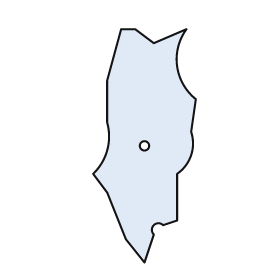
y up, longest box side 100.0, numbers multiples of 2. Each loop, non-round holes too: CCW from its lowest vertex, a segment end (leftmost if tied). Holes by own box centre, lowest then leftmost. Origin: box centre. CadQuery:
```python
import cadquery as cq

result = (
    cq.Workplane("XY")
    .moveTo(0.0, -50.0)
    .lineTo(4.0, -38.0)
    .threePointArc((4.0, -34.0), (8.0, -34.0))
    .lineTo(14.0, -32.0)
    .lineTo(14.0, -12.0)
    .threePointArc((20.0, -4.0), (20.0, 6.0))
    .lineTo(22.0, 20.0)
    .threePointArc((14.0, 34.0), (18.0, 50.0))
    .lineTo(4.0, 44.0)
    .lineTo(-4.0, 50.0)
    .lineTo(-10.0, 50.0)
    .lineTo(-16.0, 28.0)
    .lineTo(-16.0, 10.0)
    .threePointArc((-16.0, -2.0), (-22.0, -12.0))
    .lineTo(-16.0, -20.0)
    .lineTo(-8.0, -40.0)
    .close()
    .moveTo(0.0, 0.0)
    .circle(2.0)
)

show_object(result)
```